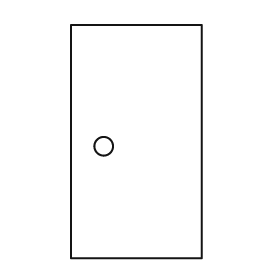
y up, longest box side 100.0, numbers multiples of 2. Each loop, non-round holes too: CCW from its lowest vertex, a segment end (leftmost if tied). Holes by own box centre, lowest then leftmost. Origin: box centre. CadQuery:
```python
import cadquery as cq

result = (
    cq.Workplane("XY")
    .moveTo(-28.0, -50.0)
    .lineTo(28.0, -50.0)
    .lineTo(28.0, 50.0)
    .lineTo(-28.0, 50.0)
    .close()
    .moveTo(-14.0, -2.0)
    .circle(4.0)
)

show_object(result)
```